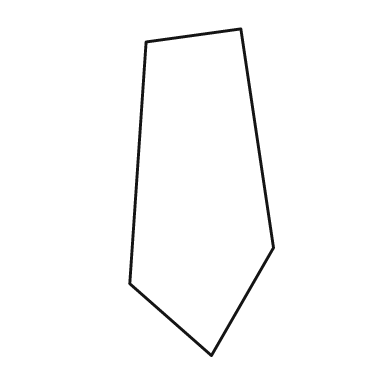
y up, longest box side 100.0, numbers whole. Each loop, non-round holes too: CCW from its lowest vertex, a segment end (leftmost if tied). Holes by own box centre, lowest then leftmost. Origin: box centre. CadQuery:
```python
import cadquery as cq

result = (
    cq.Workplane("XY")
    .moveTo(3.0, -50.0)
    .lineTo(22.0, -17.0)
    .lineTo(12.0, 50.0)
    .lineTo(-17.0, 46.0)
    .lineTo(-22.0, -28.0)
    .close()
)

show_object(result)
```